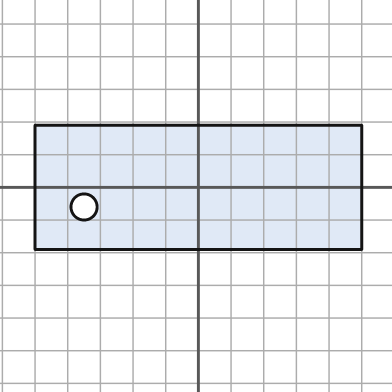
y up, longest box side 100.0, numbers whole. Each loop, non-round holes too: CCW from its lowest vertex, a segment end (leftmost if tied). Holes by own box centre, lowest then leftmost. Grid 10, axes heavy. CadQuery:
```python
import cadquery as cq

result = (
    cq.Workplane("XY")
    .moveTo(-50.0, -19.0)
    .lineTo(50.0, -19.0)
    .lineTo(50.0, 19.0)
    .lineTo(-50.0, 19.0)
    .close()
    .moveTo(-35.0, -6.0)
    .circle(4.0)
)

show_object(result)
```